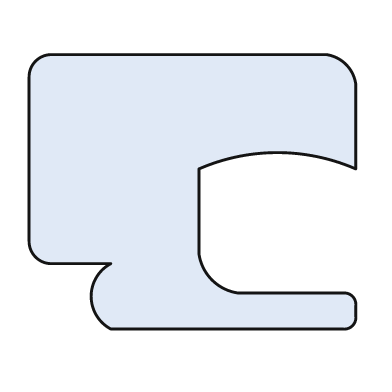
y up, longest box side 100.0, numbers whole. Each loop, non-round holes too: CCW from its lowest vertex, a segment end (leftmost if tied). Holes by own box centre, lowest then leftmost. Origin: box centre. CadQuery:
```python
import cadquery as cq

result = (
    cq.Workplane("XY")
    .moveTo(-25.0, -42.0)
    .lineTo(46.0, -42.0)
    .threePointArc((49.0, -41.0), (50.0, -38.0))
    .lineTo(50.0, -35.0)
    .threePointArc((49.0, -32.0), (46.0, -31.0))
    .lineTo(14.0, -31.0)
    .threePointArc((6.0, -27.0), (2.0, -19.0))
    .lineTo(2.0, 7.0)
    .threePointArc((26.0, 12.0), (50.0, 7.0))
    .lineTo(50.0, 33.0)
    .threePointArc((47.0, 39.0), (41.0, 42.0))
    .lineTo(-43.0, 42.0)
    .threePointArc((-48.0, 40.0), (-50.0, 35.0))
    .lineTo(-50.0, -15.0)
    .threePointArc((-48.0, -20.0), (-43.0, -22.0))
    .lineTo(-25.0, -22.0)
    .threePointArc((-31.0, -32.0), (-25.0, -42.0))
    .close()
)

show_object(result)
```